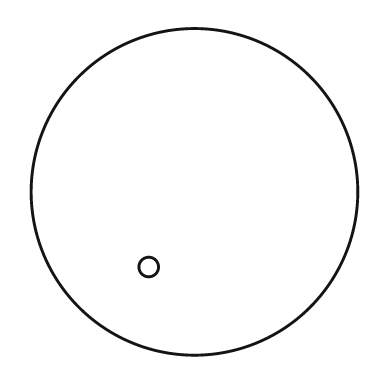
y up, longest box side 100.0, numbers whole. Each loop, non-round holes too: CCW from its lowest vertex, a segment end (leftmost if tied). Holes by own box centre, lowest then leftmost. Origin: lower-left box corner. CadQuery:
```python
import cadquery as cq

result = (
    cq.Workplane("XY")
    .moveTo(50.0, 50.0)
    .circle(50.0)
    .moveTo(36.0, 27.0)
    .circle(3.0)
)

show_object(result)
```